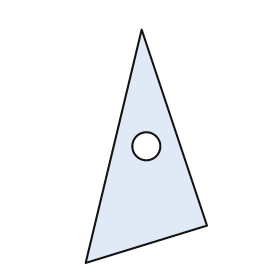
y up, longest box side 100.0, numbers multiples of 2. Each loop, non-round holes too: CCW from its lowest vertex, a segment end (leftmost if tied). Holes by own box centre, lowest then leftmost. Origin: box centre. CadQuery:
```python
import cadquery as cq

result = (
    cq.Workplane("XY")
    .moveTo(-26.0, -50.0)
    .lineTo(26.0, -34.0)
    .lineTo(-2.0, 50.0)
    .close()
    .moveTo(0.0, 0.0)
    .circle(6.0)
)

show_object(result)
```